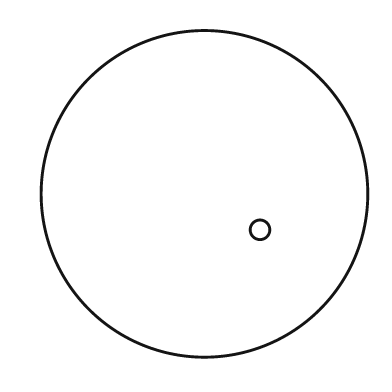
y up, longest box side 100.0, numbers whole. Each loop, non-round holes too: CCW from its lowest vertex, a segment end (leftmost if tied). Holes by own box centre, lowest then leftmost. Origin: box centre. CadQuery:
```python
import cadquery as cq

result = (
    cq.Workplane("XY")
    .moveTo(0.0, 0.0)
    .circle(50.0)
    .moveTo(17.0, -11.0)
    .circle(3.0)
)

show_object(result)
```